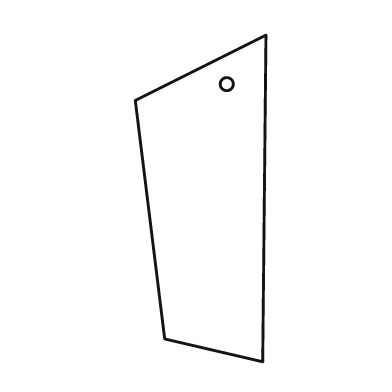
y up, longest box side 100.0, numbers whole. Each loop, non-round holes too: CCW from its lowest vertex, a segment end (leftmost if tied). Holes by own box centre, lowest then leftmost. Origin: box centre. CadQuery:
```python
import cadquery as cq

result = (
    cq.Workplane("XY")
    .moveTo(19.0, -50.0)
    .lineTo(20.0, 50.0)
    .lineTo(-20.0, 30.0)
    .lineTo(-11.0, -43.0)
    .close()
    .moveTo(8.0, 35.0)
    .circle(2.0)
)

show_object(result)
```